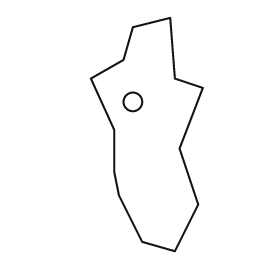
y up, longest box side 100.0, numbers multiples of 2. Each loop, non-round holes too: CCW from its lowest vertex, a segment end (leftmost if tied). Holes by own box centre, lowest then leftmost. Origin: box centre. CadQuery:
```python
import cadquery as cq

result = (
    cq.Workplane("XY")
    .moveTo(12.0, -50.0)
    .lineTo(22.0, -30.0)
    .lineTo(14.0, -6.0)
    .lineTo(24.0, 20.0)
    .lineTo(12.0, 24.0)
    .lineTo(10.0, 50.0)
    .lineTo(-6.0, 46.0)
    .lineTo(-10.0, 32.0)
    .lineTo(-24.0, 24.0)
    .lineTo(-14.0, 2.0)
    .lineTo(-14.0, -16.0)
    .lineTo(-12.0, -26.0)
    .lineTo(-2.0, -46.0)
    .close()
    .moveTo(-6.0, 14.0)
    .circle(4.0)
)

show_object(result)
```